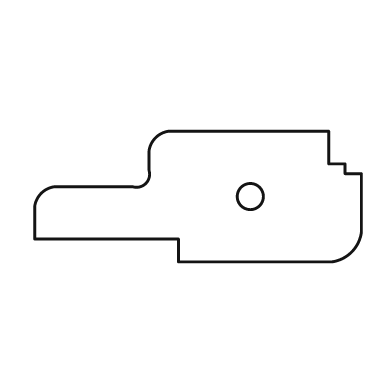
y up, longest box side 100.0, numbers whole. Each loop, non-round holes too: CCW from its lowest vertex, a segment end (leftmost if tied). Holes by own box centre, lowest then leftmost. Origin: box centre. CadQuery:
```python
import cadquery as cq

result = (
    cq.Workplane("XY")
    .moveTo(-6.0, -20.0)
    .lineTo(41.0, -20.0)
    .threePointArc((47.0, -17.0), (50.0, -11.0))
    .lineTo(50.0, 7.0)
    .lineTo(45.0, 7.0)
    .lineTo(45.0, 10.0)
    .lineTo(40.0, 10.0)
    .lineTo(40.0, 20.0)
    .lineTo(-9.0, 20.0)
    .threePointArc((-13.0, 18.0), (-15.0, 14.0))
    .lineTo(-15.0, 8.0)
    .threePointArc((-16.0, 4.0), (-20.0, 3.0))
    .lineTo(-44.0, 3.0)
    .threePointArc((-48.0, 1.0), (-50.0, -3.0))
    .lineTo(-50.0, -13.0)
    .lineTo(-6.0, -13.0)
    .close()
    .moveTo(16.0, 0.0)
    .circle(4.0)
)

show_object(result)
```